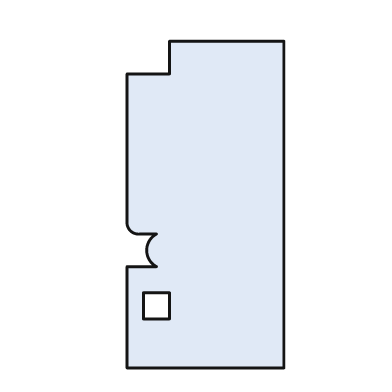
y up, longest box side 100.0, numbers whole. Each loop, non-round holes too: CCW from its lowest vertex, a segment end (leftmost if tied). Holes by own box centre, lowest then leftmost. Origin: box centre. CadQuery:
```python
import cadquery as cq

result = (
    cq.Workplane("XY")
    .moveTo(-24.0, -50.0)
    .lineTo(24.0, -50.0)
    .lineTo(24.0, 50.0)
    .lineTo(-11.0, 50.0)
    .lineTo(-11.0, 40.0)
    .lineTo(-24.0, 40.0)
    .lineTo(-24.0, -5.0)
    .threePointArc((-23.0, -8.0), (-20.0, -9.0))
    .lineTo(-15.0, -9.0)
    .threePointArc((-18.0, -14.0), (-15.0, -19.0))
    .lineTo(-24.0, -19.0)
    .close()
    .moveTo(-19.0, -35.0)
    .lineTo(-11.0, -35.0)
    .lineTo(-11.0, -27.0)
    .lineTo(-19.0, -27.0)
    .close()
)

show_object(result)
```